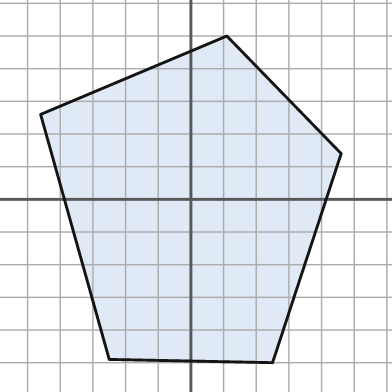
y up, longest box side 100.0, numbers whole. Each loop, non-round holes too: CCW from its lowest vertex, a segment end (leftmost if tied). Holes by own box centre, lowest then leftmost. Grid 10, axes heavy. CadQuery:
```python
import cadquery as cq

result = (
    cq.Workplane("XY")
    .moveTo(25.0, -50.0)
    .lineTo(46.0, 14.0)
    .lineTo(11.0, 50.0)
    .lineTo(-46.0, 26.0)
    .lineTo(-25.0, -49.0)
    .close()
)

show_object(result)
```